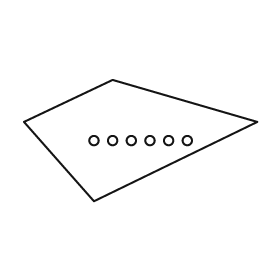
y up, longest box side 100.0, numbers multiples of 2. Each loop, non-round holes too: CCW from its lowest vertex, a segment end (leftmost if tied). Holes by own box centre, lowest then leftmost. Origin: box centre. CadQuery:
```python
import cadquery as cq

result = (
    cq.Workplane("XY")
    .moveTo(-20.0, -26.0)
    .lineTo(50.0, 8.0)
    .lineTo(-12.0, 26.0)
    .lineTo(-50.0, 8.0)
    .close()
    .moveTo(-20.0, 0.0)
    .circle(2.0)
    .moveTo(-12.0, 0.0)
    .circle(2.0)
    .moveTo(-4.0, 0.0)
    .circle(2.0)
    .moveTo(4.0, 0.0)
    .circle(2.0)
    .moveTo(12.0, 0.0)
    .circle(2.0)
    .moveTo(20.0, 0.0)
    .circle(2.0)
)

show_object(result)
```